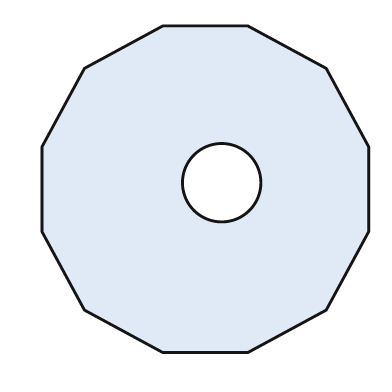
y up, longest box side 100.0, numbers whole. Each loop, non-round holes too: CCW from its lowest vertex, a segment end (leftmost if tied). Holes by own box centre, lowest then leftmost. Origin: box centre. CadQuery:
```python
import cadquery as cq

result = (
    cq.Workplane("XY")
    .moveTo(-13.0, -50.0)
    .lineTo(13.0, -50.0)
    .lineTo(37.0, -37.0)
    .lineTo(50.0, -13.0)
    .lineTo(50.0, 13.0)
    .lineTo(37.0, 37.0)
    .lineTo(13.0, 50.0)
    .lineTo(-13.0, 50.0)
    .lineTo(-37.0, 37.0)
    .lineTo(-50.0, 13.0)
    .lineTo(-50.0, -13.0)
    .lineTo(-37.0, -37.0)
    .close()
    .moveTo(5.0, 2.0)
    .circle(12.0)
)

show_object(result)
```